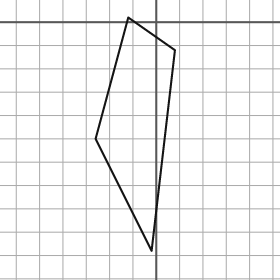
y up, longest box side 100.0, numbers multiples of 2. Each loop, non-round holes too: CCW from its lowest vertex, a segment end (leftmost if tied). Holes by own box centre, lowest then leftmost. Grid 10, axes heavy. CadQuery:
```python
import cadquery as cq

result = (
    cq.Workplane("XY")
    .moveTo(-2.0, -98.0)
    .lineTo(8.0, -12.0)
    .lineTo(-12.0, 2.0)
    .lineTo(-26.0, -50.0)
    .close()
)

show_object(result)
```